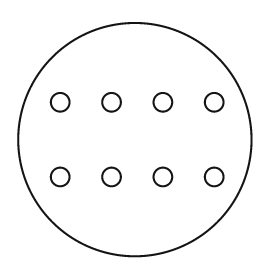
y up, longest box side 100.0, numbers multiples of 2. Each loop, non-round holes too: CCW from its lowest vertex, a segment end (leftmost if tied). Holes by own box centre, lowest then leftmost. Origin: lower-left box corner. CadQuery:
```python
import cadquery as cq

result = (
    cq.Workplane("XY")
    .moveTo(50.0, 50.0)
    .circle(50.0)
    .moveTo(18.0, 34.0)
    .circle(4.0)
    .moveTo(40.0, 34.0)
    .circle(4.0)
    .moveTo(62.0, 34.0)
    .circle(4.0)
    .moveTo(84.0, 34.0)
    .circle(4.0)
    .moveTo(18.0, 66.0)
    .circle(4.0)
    .moveTo(40.0, 66.0)
    .circle(4.0)
    .moveTo(62.0, 66.0)
    .circle(4.0)
    .moveTo(84.0, 66.0)
    .circle(4.0)
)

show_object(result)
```